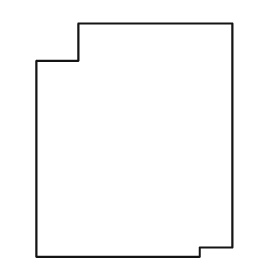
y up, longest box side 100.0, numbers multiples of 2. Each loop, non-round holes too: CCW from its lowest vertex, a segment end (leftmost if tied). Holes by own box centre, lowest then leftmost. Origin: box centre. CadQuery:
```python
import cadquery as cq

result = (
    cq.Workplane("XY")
    .moveTo(-42.0, -50.0)
    .lineTo(28.0, -50.0)
    .lineTo(28.0, -46.0)
    .lineTo(42.0, -46.0)
    .lineTo(42.0, 50.0)
    .lineTo(-24.0, 50.0)
    .lineTo(-24.0, 34.0)
    .lineTo(-42.0, 34.0)
    .close()
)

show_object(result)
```